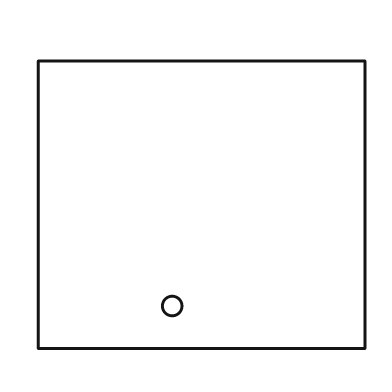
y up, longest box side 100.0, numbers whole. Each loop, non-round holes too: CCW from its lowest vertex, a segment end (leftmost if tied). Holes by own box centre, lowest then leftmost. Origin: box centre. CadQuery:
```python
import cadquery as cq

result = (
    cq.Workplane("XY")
    .moveTo(-50.0, -44.0)
    .lineTo(50.0, -44.0)
    .lineTo(50.0, 44.0)
    .lineTo(-50.0, 44.0)
    .close()
    .moveTo(-9.0, -31.0)
    .circle(3.0)
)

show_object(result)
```